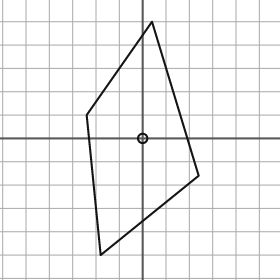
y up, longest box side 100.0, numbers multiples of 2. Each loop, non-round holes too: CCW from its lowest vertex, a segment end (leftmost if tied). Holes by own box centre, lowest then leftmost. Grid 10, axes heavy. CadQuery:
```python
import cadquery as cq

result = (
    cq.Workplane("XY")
    .moveTo(-18.0, -50.0)
    .lineTo(24.0, -16.0)
    .lineTo(4.0, 50.0)
    .lineTo(-24.0, 10.0)
    .close()
    .moveTo(0.0, 0.0)
    .circle(2.0)
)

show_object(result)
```